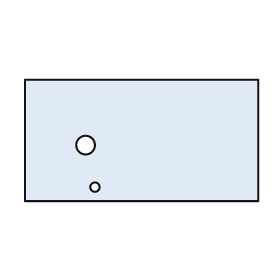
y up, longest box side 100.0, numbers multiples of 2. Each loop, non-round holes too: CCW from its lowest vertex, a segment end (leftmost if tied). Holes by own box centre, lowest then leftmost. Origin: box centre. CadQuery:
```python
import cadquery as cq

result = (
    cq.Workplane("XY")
    .moveTo(-50.0, -26.0)
    .lineTo(50.0, -26.0)
    .lineTo(50.0, 26.0)
    .lineTo(-50.0, 26.0)
    .close()
    .moveTo(-20.0, -20.0)
    .circle(2.0)
    .moveTo(-24.0, -2.0)
    .circle(4.0)
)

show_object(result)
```